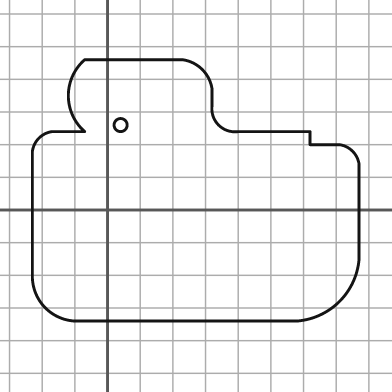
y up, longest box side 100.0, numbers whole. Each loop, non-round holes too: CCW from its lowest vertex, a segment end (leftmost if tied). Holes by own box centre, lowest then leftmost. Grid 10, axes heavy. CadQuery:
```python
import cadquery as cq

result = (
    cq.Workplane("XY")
    .moveTo(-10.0, -34.0)
    .lineTo(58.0, -34.0)
    .threePointArc((71.0, -28.0), (77.0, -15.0))
    .lineTo(77.0, 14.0)
    .threePointArc((75.0, 18.0), (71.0, 20.0))
    .lineTo(62.0, 20.0)
    .lineTo(62.0, 24.0)
    .lineTo(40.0, 24.0)
    .threePointArc((34.0, 26.0), (32.0, 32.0))
    .lineTo(32.0, 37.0)
    .threePointArc((29.0, 43.0), (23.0, 46.0))
    .lineTo(-7.0, 46.0)
    .threePointArc((-12.0, 35.0), (-7.0, 24.0))
    .lineTo(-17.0, 24.0)
    .threePointArc((-21.0, 22.0), (-23.0, 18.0))
    .lineTo(-23.0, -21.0)
    .threePointArc((-19.0, -30.0), (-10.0, -34.0))
    .close()
    .moveTo(4.0, 26.0)
    .circle(2.0)
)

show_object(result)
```